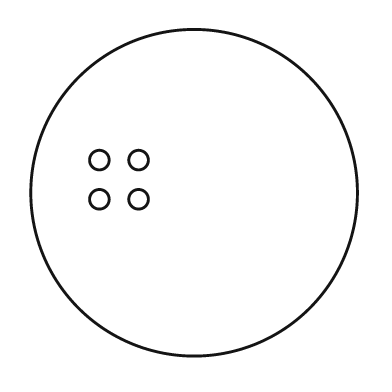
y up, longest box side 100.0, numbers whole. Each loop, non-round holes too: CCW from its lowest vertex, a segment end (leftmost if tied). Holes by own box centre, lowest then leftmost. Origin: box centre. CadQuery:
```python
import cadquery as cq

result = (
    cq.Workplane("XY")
    .moveTo(0.0, 0.0)
    .circle(50.0)
    .moveTo(-29.0, -2.0)
    .circle(3.0)
    .moveTo(-17.0, -2.0)
    .circle(3.0)
    .moveTo(-29.0, 10.0)
    .circle(3.0)
    .moveTo(-17.0, 10.0)
    .circle(3.0)
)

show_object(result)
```